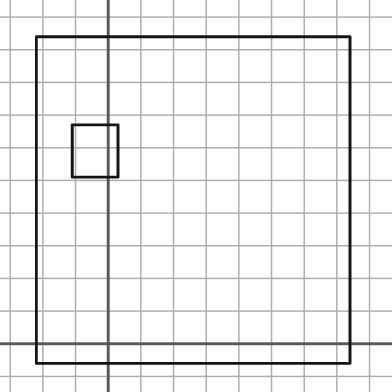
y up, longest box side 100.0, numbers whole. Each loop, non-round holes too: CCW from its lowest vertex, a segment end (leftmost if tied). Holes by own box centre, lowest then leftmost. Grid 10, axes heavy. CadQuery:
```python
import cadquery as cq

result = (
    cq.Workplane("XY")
    .moveTo(-22.0, -6.0)
    .lineTo(74.0, -6.0)
    .lineTo(74.0, 94.0)
    .lineTo(-22.0, 94.0)
    .close()
    .moveTo(-11.0, 51.0)
    .lineTo(3.0, 51.0)
    .lineTo(3.0, 67.0)
    .lineTo(-11.0, 67.0)
    .close()
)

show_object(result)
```